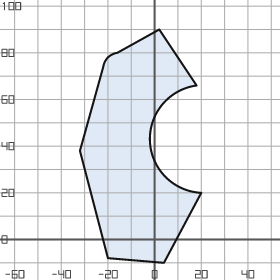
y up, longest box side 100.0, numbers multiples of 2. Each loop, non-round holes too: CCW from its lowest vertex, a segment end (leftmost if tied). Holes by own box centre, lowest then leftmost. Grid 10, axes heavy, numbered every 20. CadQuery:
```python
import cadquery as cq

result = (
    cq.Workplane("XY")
    .moveTo(4.0, -10.0)
    .lineTo(20.0, 20.0)
    .threePointArc((-2.0, 42.0), (18.0, 66.0))
    .lineTo(2.0, 90.0)
    .lineTo(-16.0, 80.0)
    .threePointArc((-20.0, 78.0), (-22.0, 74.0))
    .lineTo(-32.0, 38.0)
    .lineTo(-20.0, -8.0)
    .close()
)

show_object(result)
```